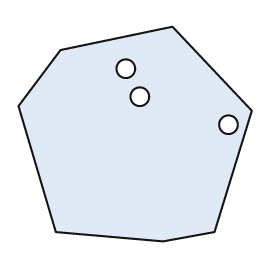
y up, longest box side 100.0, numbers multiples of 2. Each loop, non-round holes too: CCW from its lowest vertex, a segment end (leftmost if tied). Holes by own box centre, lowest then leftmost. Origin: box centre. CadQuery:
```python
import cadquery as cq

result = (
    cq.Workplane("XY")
    .moveTo(12.0, -46.0)
    .lineTo(34.0, -42.0)
    .lineTo(50.0, 10.0)
    .lineTo(16.0, 46.0)
    .lineTo(-32.0, 36.0)
    .lineTo(-50.0, 12.0)
    .lineTo(-34.0, -42.0)
    .close()
    .moveTo(40.0, 4.0)
    .circle(4.0)
    .moveTo(2.0, 16.0)
    .circle(4.0)
    .moveTo(-4.0, 28.0)
    .circle(4.0)
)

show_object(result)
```